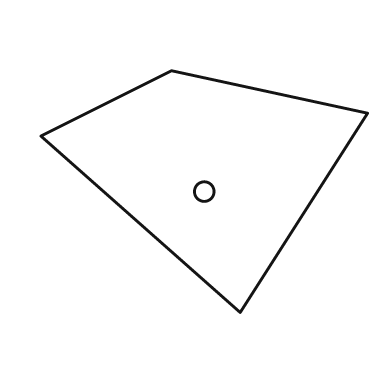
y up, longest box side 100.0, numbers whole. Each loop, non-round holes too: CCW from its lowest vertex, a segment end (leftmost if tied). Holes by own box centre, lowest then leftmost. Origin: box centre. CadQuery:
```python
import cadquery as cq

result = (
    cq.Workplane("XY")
    .moveTo(11.0, -37.0)
    .lineTo(50.0, 24.0)
    .lineTo(-10.0, 37.0)
    .lineTo(-50.0, 17.0)
    .close()
    .moveTo(0.0, 0.0)
    .circle(3.0)
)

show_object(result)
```